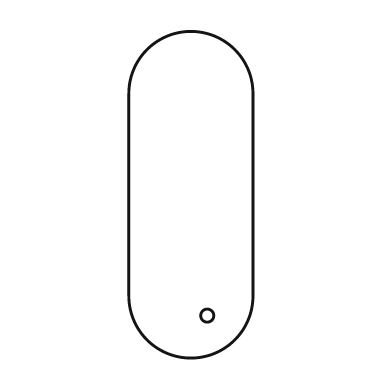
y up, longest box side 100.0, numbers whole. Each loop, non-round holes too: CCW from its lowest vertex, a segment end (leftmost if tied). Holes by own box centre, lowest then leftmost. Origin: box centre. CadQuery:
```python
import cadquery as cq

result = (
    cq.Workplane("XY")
    .moveTo(-19.0, -31.0)
    .threePointArc((0.0, -50.0), (19.0, -31.0))
    .lineTo(19.0, 31.0)
    .threePointArc((0.0, 50.0), (-19.0, 31.0))
    .close()
    .moveTo(5.0, -37.0)
    .circle(2.0)
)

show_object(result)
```